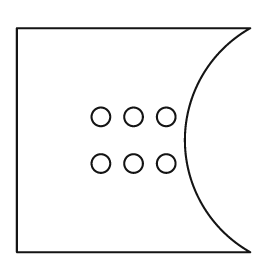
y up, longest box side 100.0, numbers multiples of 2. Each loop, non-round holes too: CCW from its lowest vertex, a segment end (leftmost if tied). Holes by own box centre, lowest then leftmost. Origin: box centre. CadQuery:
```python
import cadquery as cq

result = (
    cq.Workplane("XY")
    .moveTo(-50.0, -48.0)
    .lineTo(50.0, -48.0)
    .threePointArc((22.0, 0.0), (50.0, 48.0))
    .lineTo(-50.0, 48.0)
    .close()
    .moveTo(-14.0, -10.0)
    .circle(4.0)
    .moveTo(0.0, -10.0)
    .circle(4.0)
    .moveTo(14.0, -10.0)
    .circle(4.0)
    .moveTo(-14.0, 10.0)
    .circle(4.0)
    .moveTo(0.0, 10.0)
    .circle(4.0)
    .moveTo(14.0, 10.0)
    .circle(4.0)
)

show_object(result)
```